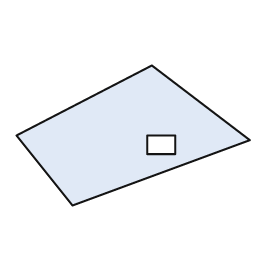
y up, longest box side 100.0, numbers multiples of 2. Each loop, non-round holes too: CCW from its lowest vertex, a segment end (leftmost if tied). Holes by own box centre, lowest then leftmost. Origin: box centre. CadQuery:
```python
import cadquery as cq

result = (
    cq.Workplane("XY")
    .moveTo(-26.0, -30.0)
    .lineTo(50.0, -2.0)
    .lineTo(8.0, 30.0)
    .lineTo(-50.0, 0.0)
    .close()
    .moveTo(6.0, -8.0)
    .lineTo(18.0, -8.0)
    .lineTo(18.0, 0.0)
    .lineTo(6.0, 0.0)
    .close()
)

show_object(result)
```